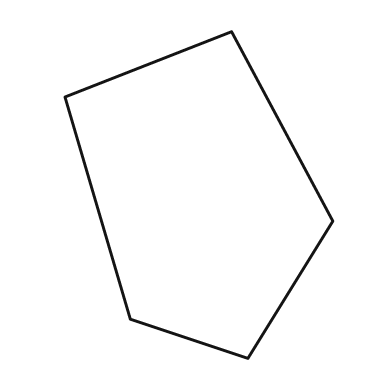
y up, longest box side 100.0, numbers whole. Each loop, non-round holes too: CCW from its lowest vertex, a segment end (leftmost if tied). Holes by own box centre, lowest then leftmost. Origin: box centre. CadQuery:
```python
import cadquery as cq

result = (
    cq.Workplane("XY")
    .moveTo(15.0, -50.0)
    .lineTo(41.0, -8.0)
    .lineTo(10.0, 50.0)
    .lineTo(-41.0, 30.0)
    .lineTo(-21.0, -38.0)
    .close()
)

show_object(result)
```